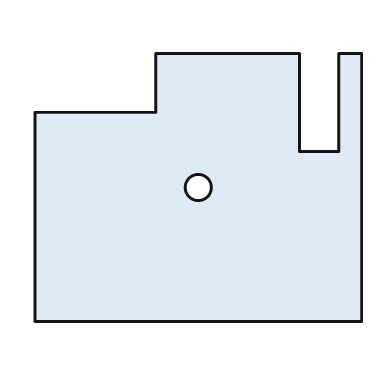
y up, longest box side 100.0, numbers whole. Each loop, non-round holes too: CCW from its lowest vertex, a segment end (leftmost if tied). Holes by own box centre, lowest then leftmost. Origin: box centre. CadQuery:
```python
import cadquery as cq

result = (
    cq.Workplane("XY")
    .moveTo(-50.0, -41.0)
    .lineTo(50.0, -41.0)
    .lineTo(50.0, 41.0)
    .lineTo(43.0, 41.0)
    .lineTo(43.0, 11.0)
    .lineTo(31.0, 11.0)
    .lineTo(31.0, 41.0)
    .lineTo(-13.0, 41.0)
    .lineTo(-13.0, 23.0)
    .lineTo(-50.0, 23.0)
    .close()
    .moveTo(0.0, 0.0)
    .circle(4.0)
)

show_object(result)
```